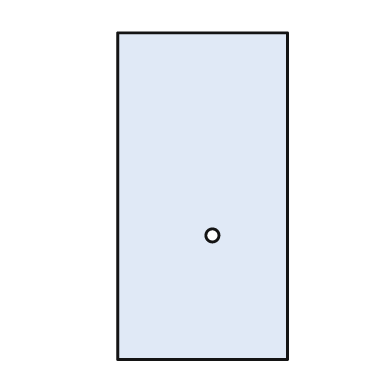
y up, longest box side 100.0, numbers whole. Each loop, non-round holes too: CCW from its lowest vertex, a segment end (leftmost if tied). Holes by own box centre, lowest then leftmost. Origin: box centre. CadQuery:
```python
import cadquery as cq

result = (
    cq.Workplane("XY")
    .moveTo(-26.0, -50.0)
    .lineTo(26.0, -50.0)
    .lineTo(26.0, 50.0)
    .lineTo(-26.0, 50.0)
    .close()
    .moveTo(3.0, -12.0)
    .circle(2.0)
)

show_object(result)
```